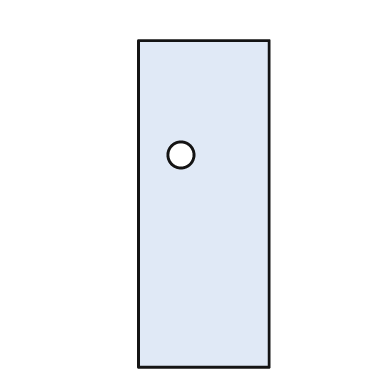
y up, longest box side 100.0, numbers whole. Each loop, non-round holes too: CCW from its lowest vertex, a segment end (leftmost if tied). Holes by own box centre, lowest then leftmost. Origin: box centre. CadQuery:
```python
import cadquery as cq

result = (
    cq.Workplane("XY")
    .moveTo(-20.0, -50.0)
    .lineTo(20.0, -50.0)
    .lineTo(20.0, 50.0)
    .lineTo(-20.0, 50.0)
    .close()
    .moveTo(-7.0, 15.0)
    .circle(4.0)
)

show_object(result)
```